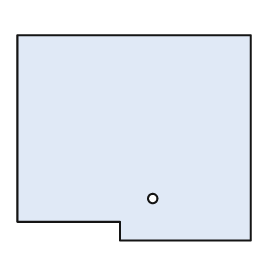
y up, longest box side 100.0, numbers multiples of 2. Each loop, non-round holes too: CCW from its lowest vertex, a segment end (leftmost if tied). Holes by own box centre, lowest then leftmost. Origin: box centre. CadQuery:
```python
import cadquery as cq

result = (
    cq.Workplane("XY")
    .moveTo(-6.0, -44.0)
    .lineTo(50.0, -44.0)
    .lineTo(50.0, 44.0)
    .lineTo(-50.0, 44.0)
    .lineTo(-50.0, -36.0)
    .lineTo(-6.0, -36.0)
    .close()
    .moveTo(8.0, -26.0)
    .circle(2.0)
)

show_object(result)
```